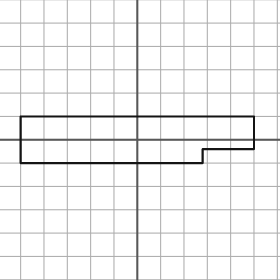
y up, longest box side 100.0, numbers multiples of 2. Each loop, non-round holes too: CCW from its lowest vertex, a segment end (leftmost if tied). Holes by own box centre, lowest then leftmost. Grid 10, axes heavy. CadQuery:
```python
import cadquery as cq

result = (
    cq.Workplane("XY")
    .moveTo(-50.0, -10.0)
    .lineTo(28.0, -10.0)
    .lineTo(28.0, -4.0)
    .lineTo(50.0, -4.0)
    .lineTo(50.0, 10.0)
    .lineTo(-50.0, 10.0)
    .close()
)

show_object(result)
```